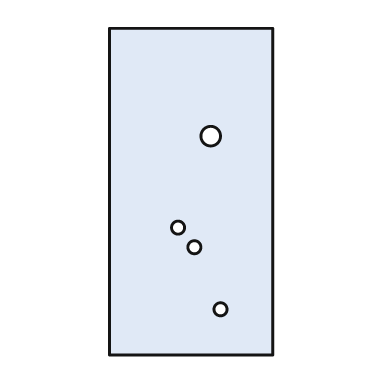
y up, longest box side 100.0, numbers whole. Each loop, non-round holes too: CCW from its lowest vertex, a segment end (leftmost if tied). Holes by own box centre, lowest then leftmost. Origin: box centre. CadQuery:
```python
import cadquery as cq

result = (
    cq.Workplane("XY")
    .moveTo(-25.0, -50.0)
    .lineTo(25.0, -50.0)
    .lineTo(25.0, 50.0)
    .lineTo(-25.0, 50.0)
    .close()
    .moveTo(9.0, -36.0)
    .circle(2.0)
    .moveTo(1.0, -17.0)
    .circle(2.0)
    .moveTo(-4.0, -11.0)
    .circle(2.0)
    .moveTo(6.0, 17.0)
    .circle(3.0)
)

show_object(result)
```